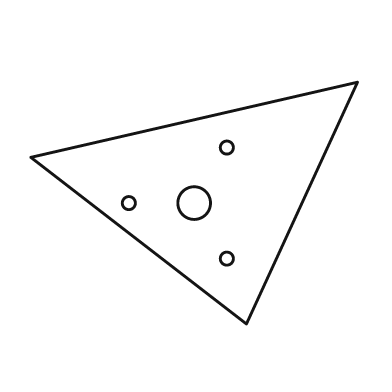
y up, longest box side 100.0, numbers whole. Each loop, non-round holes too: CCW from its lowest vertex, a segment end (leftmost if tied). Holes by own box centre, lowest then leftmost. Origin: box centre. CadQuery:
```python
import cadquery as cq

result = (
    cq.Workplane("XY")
    .moveTo(16.0, -37.0)
    .lineTo(50.0, 37.0)
    .lineTo(-50.0, 14.0)
    .close()
    .moveTo(10.0, -17.0)
    .circle(2.0)
    .moveTo(-20.0, 0.0)
    .circle(2.0)
    .moveTo(0.0, 0.0)
    .circle(5.0)
    .moveTo(10.0, 17.0)
    .circle(2.0)
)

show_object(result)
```